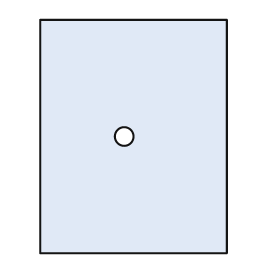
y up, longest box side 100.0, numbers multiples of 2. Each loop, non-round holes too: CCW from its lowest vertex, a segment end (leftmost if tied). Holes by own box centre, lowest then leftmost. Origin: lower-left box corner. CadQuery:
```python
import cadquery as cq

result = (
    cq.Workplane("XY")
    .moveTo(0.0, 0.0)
    .lineTo(80.0, 0.0)
    .lineTo(80.0, 100.0)
    .lineTo(0.0, 100.0)
    .close()
    .moveTo(36.0, 50.0)
    .circle(4.0)
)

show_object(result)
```